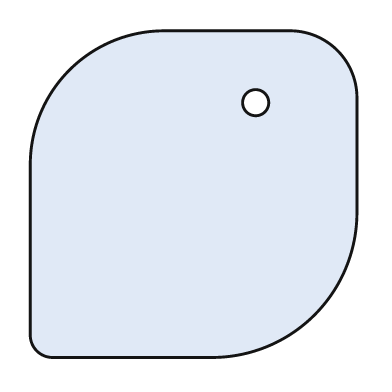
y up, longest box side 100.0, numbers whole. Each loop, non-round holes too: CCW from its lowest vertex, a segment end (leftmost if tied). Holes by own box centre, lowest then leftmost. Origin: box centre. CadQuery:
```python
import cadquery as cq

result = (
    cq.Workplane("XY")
    .moveTo(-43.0, -50.0)
    .lineTo(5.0, -50.0)
    .threePointArc((37.0, -37.0), (50.0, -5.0))
    .lineTo(50.0, 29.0)
    .threePointArc((44.0, 44.0), (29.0, 50.0))
    .lineTo(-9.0, 50.0)
    .threePointArc((-38.0, 38.0), (-50.0, 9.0))
    .lineTo(-50.0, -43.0)
    .threePointArc((-48.0, -48.0), (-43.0, -50.0))
    .close()
    .moveTo(19.0, 28.0)
    .circle(4.0)
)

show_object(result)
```